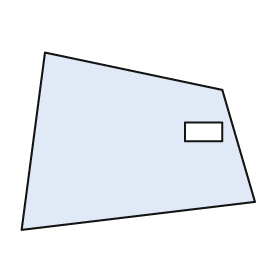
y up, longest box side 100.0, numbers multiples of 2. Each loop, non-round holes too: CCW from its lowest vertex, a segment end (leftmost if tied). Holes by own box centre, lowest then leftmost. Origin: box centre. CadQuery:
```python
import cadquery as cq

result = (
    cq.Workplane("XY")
    .moveTo(-50.0, -38.0)
    .lineTo(50.0, -26.0)
    .lineTo(36.0, 22.0)
    .lineTo(-40.0, 38.0)
    .close()
    .moveTo(20.0, 0.0)
    .lineTo(36.0, 0.0)
    .lineTo(36.0, 8.0)
    .lineTo(20.0, 8.0)
    .close()
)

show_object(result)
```